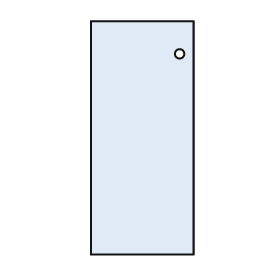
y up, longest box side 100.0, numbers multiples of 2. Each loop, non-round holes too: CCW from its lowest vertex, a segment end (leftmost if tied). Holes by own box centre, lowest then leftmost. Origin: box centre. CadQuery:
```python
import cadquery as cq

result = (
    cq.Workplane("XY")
    .moveTo(-22.0, -50.0)
    .lineTo(22.0, -50.0)
    .lineTo(22.0, 50.0)
    .lineTo(-22.0, 50.0)
    .close()
    .moveTo(16.0, 36.0)
    .circle(2.0)
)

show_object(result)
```